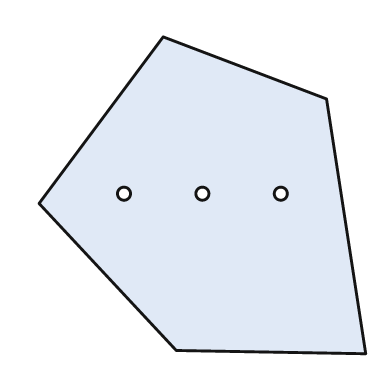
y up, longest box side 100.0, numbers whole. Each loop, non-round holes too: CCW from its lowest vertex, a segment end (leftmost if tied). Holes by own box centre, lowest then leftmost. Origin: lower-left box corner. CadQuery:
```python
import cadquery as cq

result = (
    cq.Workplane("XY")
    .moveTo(100.0, 0.0)
    .lineTo(88.0, 78.0)
    .lineTo(38.0, 97.0)
    .lineTo(0.0, 46.0)
    .lineTo(42.0, 1.0)
    .close()
    .moveTo(26.0, 49.0)
    .circle(2.0)
    .moveTo(50.0, 49.0)
    .circle(2.0)
    .moveTo(74.0, 49.0)
    .circle(2.0)
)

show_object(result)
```